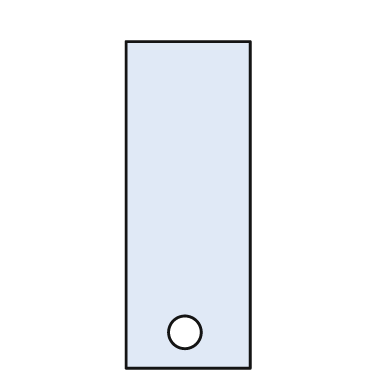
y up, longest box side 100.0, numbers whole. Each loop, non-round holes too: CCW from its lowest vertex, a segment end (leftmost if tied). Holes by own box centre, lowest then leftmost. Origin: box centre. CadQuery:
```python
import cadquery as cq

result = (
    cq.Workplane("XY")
    .moveTo(-19.0, -50.0)
    .lineTo(19.0, -50.0)
    .lineTo(19.0, 50.0)
    .lineTo(-19.0, 50.0)
    .close()
    .moveTo(-1.0, -39.0)
    .circle(5.0)
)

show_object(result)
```